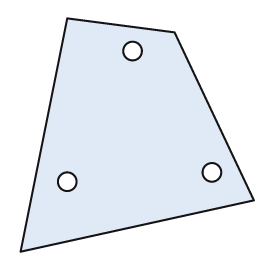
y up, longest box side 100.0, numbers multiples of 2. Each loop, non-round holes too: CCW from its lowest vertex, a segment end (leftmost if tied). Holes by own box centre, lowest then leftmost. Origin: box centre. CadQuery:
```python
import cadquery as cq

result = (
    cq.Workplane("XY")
    .moveTo(-50.0, -50.0)
    .lineTo(50.0, -28.0)
    .lineTo(16.0, 44.0)
    .lineTo(-30.0, 50.0)
    .close()
    .moveTo(-30.0, -20.0)
    .circle(4.0)
    .moveTo(32.0, -16.0)
    .circle(4.0)
    .moveTo(-2.0, 36.0)
    .circle(4.0)
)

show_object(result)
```